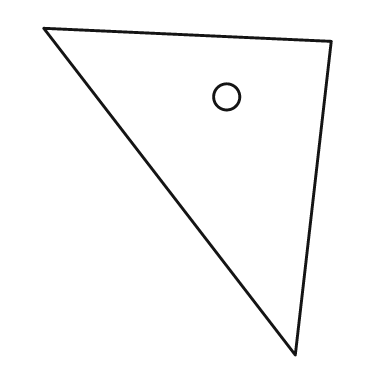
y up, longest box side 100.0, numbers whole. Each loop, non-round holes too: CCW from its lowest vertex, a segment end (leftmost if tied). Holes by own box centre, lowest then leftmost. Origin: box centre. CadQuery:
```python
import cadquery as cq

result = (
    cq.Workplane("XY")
    .moveTo(33.0, -50.0)
    .lineTo(44.0, 46.0)
    .lineTo(-44.0, 50.0)
    .close()
    .moveTo(12.0, 29.0)
    .circle(4.0)
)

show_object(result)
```